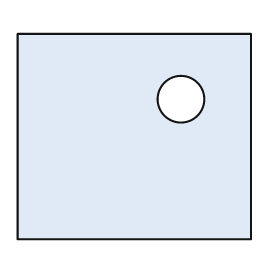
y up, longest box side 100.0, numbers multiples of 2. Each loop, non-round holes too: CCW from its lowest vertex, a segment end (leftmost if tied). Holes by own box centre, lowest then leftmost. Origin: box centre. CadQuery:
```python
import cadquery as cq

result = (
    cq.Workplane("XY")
    .moveTo(-50.0, -44.0)
    .lineTo(50.0, -44.0)
    .lineTo(50.0, 44.0)
    .lineTo(-50.0, 44.0)
    .close()
    .moveTo(20.0, 16.0)
    .circle(10.0)
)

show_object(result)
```